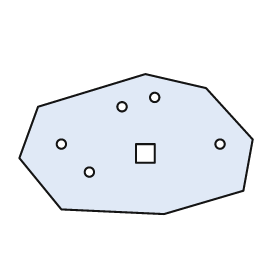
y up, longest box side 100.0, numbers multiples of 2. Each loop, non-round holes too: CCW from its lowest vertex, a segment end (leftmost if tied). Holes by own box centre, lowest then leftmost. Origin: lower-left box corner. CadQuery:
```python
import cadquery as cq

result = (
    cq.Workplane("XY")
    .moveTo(62.0, 0.0)
    .lineTo(96.0, 10.0)
    .lineTo(100.0, 32.0)
    .lineTo(80.0, 54.0)
    .lineTo(54.0, 60.0)
    .lineTo(8.0, 46.0)
    .lineTo(0.0, 24.0)
    .lineTo(18.0, 2.0)
    .close()
    .moveTo(30.0, 18.0)
    .circle(2.0)
    .moveTo(50.0, 22.0)
    .lineTo(58.0, 22.0)
    .lineTo(58.0, 30.0)
    .lineTo(50.0, 30.0)
    .close()
    .moveTo(18.0, 30.0)
    .circle(2.0)
    .moveTo(86.0, 30.0)
    .circle(2.0)
    .moveTo(44.0, 46.0)
    .circle(2.0)
    .moveTo(58.0, 50.0)
    .circle(2.0)
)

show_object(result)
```